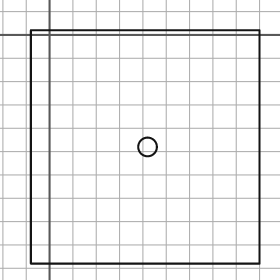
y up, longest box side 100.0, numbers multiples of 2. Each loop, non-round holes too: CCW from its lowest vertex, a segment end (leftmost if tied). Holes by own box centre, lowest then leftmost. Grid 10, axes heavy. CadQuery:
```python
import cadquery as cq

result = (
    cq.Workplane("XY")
    .moveTo(-8.0, -98.0)
    .lineTo(90.0, -98.0)
    .lineTo(90.0, 2.0)
    .lineTo(-8.0, 2.0)
    .close()
    .moveTo(42.0, -48.0)
    .circle(4.0)
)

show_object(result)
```